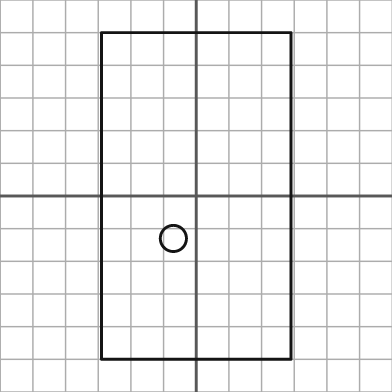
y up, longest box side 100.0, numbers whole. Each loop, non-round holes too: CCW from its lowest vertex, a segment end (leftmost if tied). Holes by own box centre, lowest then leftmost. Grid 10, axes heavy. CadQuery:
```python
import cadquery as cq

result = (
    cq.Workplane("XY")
    .moveTo(-29.0, -50.0)
    .lineTo(29.0, -50.0)
    .lineTo(29.0, 50.0)
    .lineTo(-29.0, 50.0)
    .close()
    .moveTo(-7.0, -13.0)
    .circle(4.0)
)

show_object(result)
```